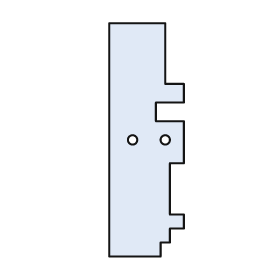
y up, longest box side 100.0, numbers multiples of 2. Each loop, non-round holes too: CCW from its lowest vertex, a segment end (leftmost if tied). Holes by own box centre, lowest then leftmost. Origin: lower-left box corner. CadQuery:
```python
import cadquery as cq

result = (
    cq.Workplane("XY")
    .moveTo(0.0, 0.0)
    .lineTo(22.0, 0.0)
    .lineTo(22.0, 6.0)
    .lineTo(26.0, 6.0)
    .lineTo(26.0, 12.0)
    .lineTo(32.0, 12.0)
    .lineTo(32.0, 18.0)
    .lineTo(26.0, 18.0)
    .lineTo(26.0, 40.0)
    .lineTo(32.0, 40.0)
    .lineTo(32.0, 58.0)
    .lineTo(20.0, 58.0)
    .lineTo(20.0, 66.0)
    .lineTo(32.0, 66.0)
    .lineTo(32.0, 74.0)
    .lineTo(24.0, 74.0)
    .lineTo(24.0, 100.0)
    .lineTo(0.0, 100.0)
    .close()
    .moveTo(10.0, 50.0)
    .circle(2.0)
    .moveTo(24.0, 50.0)
    .circle(2.0)
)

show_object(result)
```